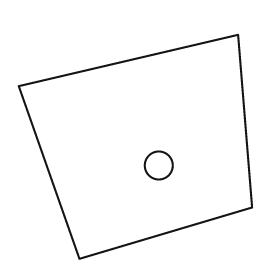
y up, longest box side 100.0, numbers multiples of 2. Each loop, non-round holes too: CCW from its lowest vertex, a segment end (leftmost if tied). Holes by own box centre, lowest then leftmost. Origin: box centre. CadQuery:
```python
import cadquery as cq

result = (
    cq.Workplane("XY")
    .moveTo(-24.0, -48.0)
    .lineTo(50.0, -26.0)
    .lineTo(44.0, 48.0)
    .lineTo(-50.0, 26.0)
    .close()
    .moveTo(10.0, -8.0)
    .circle(6.0)
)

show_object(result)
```